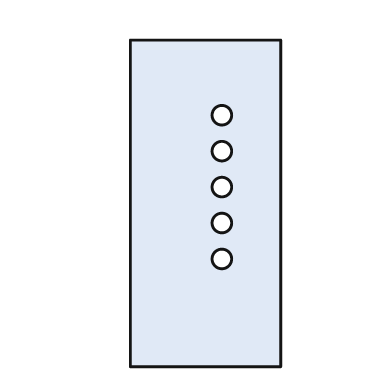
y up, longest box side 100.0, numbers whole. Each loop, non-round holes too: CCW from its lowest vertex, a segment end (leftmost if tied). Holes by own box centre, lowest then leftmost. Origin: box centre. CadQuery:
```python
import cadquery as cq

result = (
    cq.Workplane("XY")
    .moveTo(-23.0, -50.0)
    .lineTo(23.0, -50.0)
    .lineTo(23.0, 50.0)
    .lineTo(-23.0, 50.0)
    .close()
    .moveTo(5.0, -17.0)
    .circle(3.0)
    .moveTo(5.0, -6.0)
    .circle(3.0)
    .moveTo(5.0, 5.0)
    .circle(3.0)
    .moveTo(5.0, 16.0)
    .circle(3.0)
    .moveTo(5.0, 27.0)
    .circle(3.0)
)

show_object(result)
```